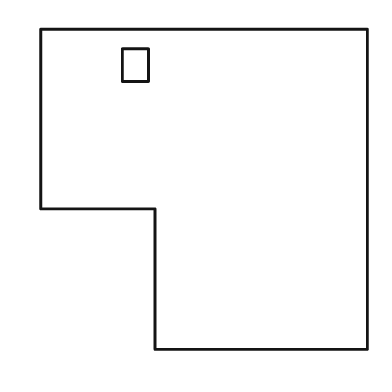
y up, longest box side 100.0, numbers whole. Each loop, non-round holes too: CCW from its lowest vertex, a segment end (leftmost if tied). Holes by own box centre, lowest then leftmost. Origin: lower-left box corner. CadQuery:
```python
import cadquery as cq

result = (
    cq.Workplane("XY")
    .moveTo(35.0, 0.0)
    .lineTo(100.0, 0.0)
    .lineTo(100.0, 98.0)
    .lineTo(0.0, 98.0)
    .lineTo(0.0, 43.0)
    .lineTo(35.0, 43.0)
    .close()
    .moveTo(25.0, 82.0)
    .lineTo(33.0, 82.0)
    .lineTo(33.0, 92.0)
    .lineTo(25.0, 92.0)
    .close()
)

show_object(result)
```